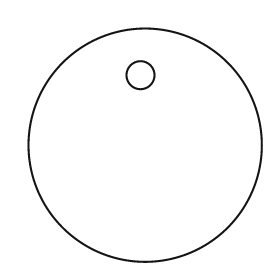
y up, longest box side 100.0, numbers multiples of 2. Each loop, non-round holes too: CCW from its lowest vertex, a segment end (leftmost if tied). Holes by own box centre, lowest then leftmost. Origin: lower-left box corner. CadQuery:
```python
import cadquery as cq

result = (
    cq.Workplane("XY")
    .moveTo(50.0, 50.0)
    .circle(50.0)
    .moveTo(48.0, 80.0)
    .circle(6.0)
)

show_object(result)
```